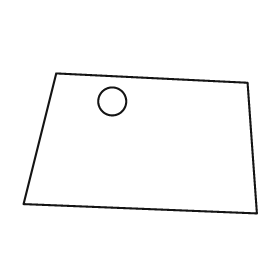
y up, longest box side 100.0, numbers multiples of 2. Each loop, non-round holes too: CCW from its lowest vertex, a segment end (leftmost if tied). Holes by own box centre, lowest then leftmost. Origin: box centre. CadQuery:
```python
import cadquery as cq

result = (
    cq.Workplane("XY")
    .moveTo(50.0, -30.0)
    .lineTo(46.0, 26.0)
    .lineTo(-36.0, 30.0)
    .lineTo(-50.0, -26.0)
    .close()
    .moveTo(-12.0, 18.0)
    .circle(6.0)
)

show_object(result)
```